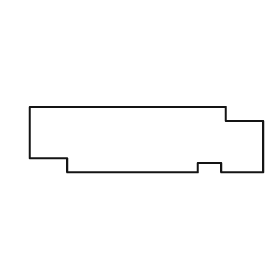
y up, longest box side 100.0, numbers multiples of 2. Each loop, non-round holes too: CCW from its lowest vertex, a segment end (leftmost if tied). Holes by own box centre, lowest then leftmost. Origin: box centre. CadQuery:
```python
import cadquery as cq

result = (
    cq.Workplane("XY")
    .moveTo(-34.0, -14.0)
    .lineTo(22.0, -14.0)
    .lineTo(22.0, -10.0)
    .lineTo(32.0, -10.0)
    .lineTo(32.0, -14.0)
    .lineTo(50.0, -14.0)
    .lineTo(50.0, 8.0)
    .lineTo(34.0, 8.0)
    .lineTo(34.0, 14.0)
    .lineTo(-50.0, 14.0)
    .lineTo(-50.0, -8.0)
    .lineTo(-34.0, -8.0)
    .close()
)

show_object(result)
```